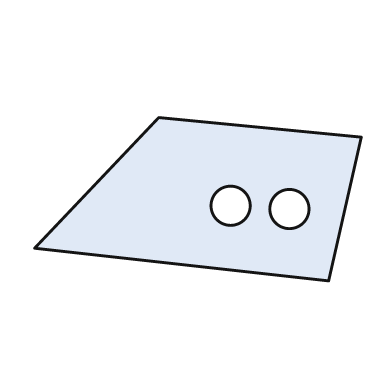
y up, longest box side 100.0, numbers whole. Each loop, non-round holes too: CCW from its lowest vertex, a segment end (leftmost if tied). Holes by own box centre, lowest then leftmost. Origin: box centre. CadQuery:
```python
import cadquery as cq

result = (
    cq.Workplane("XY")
    .moveTo(40.0, -25.0)
    .lineTo(50.0, 19.0)
    .lineTo(-12.0, 25.0)
    .lineTo(-50.0, -15.0)
    .close()
    .moveTo(28.0, -3.0)
    .circle(6.0)
    .moveTo(10.0, -2.0)
    .circle(6.0)
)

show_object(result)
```